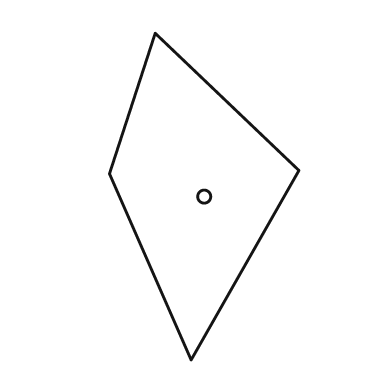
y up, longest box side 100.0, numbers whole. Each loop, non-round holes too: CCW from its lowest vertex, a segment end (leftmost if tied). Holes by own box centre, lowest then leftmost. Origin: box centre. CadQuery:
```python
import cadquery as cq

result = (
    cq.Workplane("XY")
    .moveTo(-4.0, -50.0)
    .lineTo(29.0, 8.0)
    .lineTo(-15.0, 50.0)
    .lineTo(-29.0, 7.0)
    .close()
    .moveTo(0.0, 0.0)
    .circle(2.0)
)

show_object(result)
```